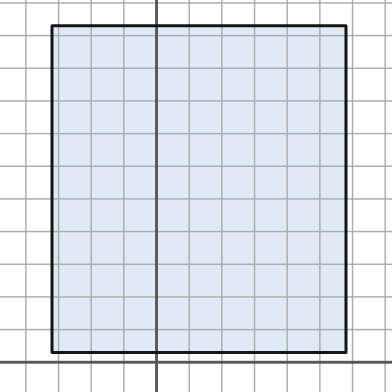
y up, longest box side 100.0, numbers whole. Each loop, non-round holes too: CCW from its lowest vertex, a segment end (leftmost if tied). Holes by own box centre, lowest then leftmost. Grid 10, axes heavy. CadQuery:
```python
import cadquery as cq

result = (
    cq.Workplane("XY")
    .moveTo(-32.0, 3.0)
    .lineTo(58.0, 3.0)
    .lineTo(58.0, 103.0)
    .lineTo(-32.0, 103.0)
    .close()
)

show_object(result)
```